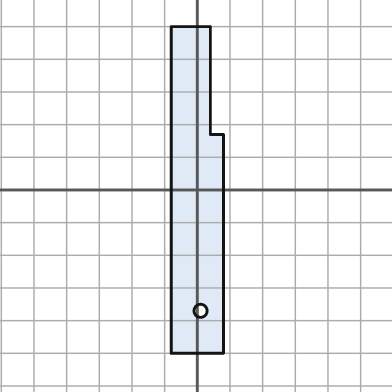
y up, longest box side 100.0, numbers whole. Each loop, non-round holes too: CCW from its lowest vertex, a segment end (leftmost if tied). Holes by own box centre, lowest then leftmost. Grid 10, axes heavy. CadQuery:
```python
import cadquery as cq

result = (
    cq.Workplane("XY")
    .moveTo(-8.0, -50.0)
    .lineTo(8.0, -50.0)
    .lineTo(8.0, 17.0)
    .lineTo(4.0, 17.0)
    .lineTo(4.0, 50.0)
    .lineTo(-8.0, 50.0)
    .close()
    .moveTo(1.0, -37.0)
    .circle(2.0)
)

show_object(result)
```